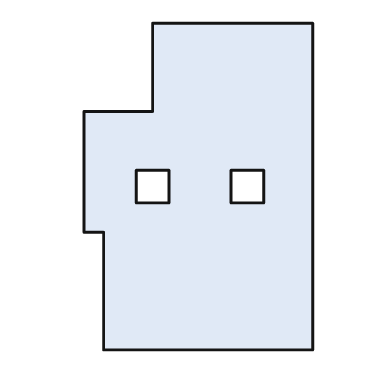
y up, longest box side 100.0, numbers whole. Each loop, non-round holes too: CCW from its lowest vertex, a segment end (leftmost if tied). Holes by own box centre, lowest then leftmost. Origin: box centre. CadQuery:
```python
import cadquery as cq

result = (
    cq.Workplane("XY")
    .moveTo(-29.0, -50.0)
    .lineTo(35.0, -50.0)
    .lineTo(35.0, 50.0)
    .lineTo(-14.0, 50.0)
    .lineTo(-14.0, 23.0)
    .lineTo(-35.0, 23.0)
    .lineTo(-35.0, -14.0)
    .lineTo(-29.0, -14.0)
    .close()
    .moveTo(-19.0, -5.0)
    .lineTo(-9.0, -5.0)
    .lineTo(-9.0, 5.0)
    .lineTo(-19.0, 5.0)
    .close()
    .moveTo(10.0, -5.0)
    .lineTo(20.0, -5.0)
    .lineTo(20.0, 5.0)
    .lineTo(10.0, 5.0)
    .close()
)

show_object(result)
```